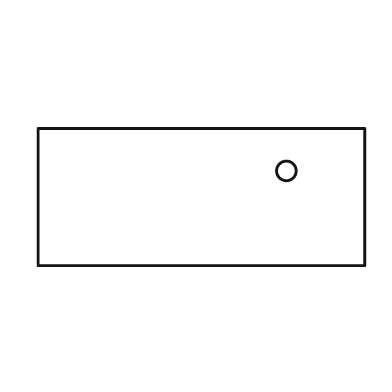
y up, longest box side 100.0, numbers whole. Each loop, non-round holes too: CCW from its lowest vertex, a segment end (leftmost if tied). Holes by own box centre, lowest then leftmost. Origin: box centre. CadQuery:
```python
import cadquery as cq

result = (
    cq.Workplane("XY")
    .moveTo(-50.0, -21.0)
    .lineTo(50.0, -21.0)
    .lineTo(50.0, 21.0)
    .lineTo(-50.0, 21.0)
    .close()
    .moveTo(26.0, 8.0)
    .circle(3.0)
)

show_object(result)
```